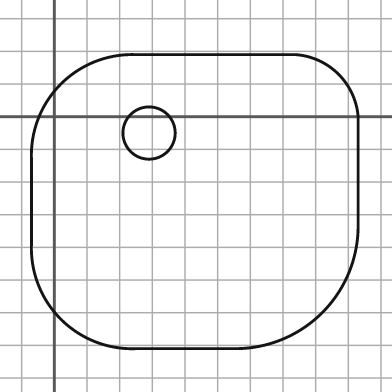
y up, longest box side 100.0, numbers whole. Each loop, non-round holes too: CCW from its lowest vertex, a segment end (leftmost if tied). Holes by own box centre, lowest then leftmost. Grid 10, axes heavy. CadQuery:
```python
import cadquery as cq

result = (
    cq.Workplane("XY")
    .moveTo(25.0, -71.0)
    .lineTo(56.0, -71.0)
    .threePointArc((82.0, -60.0), (93.0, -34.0))
    .lineTo(93.0, 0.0)
    .threePointArc((87.0, 13.0), (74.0, 19.0))
    .lineTo(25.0, 19.0)
    .threePointArc((2.0, 10.0), (-7.0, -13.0))
    .lineTo(-7.0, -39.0)
    .threePointArc((2.0, -62.0), (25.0, -71.0))
    .close()
    .moveTo(29.0, -5.0)
    .circle(8.0)
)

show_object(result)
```